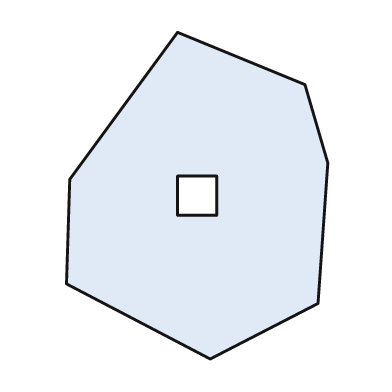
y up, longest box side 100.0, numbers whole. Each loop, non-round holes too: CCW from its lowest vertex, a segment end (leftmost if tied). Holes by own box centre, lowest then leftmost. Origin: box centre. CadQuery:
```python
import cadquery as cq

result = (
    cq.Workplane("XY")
    .moveTo(4.0, -50.0)
    .lineTo(37.0, -33.0)
    .lineTo(40.0, 10.0)
    .lineTo(33.0, 34.0)
    .lineTo(-6.0, 50.0)
    .lineTo(-39.0, 5.0)
    .lineTo(-40.0, -27.0)
    .close()
    .moveTo(-6.0, -6.0)
    .lineTo(6.0, -6.0)
    .lineTo(6.0, 6.0)
    .lineTo(-6.0, 6.0)
    .close()
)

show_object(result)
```